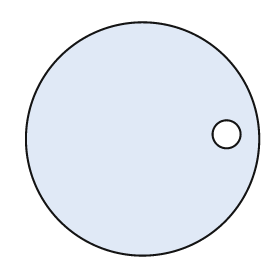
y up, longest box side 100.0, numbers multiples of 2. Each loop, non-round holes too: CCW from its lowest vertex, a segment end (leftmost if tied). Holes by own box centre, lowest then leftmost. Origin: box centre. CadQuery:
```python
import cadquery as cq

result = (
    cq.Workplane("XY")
    .moveTo(0.0, 0.0)
    .circle(50.0)
    .moveTo(36.0, 2.0)
    .circle(6.0)
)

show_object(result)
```